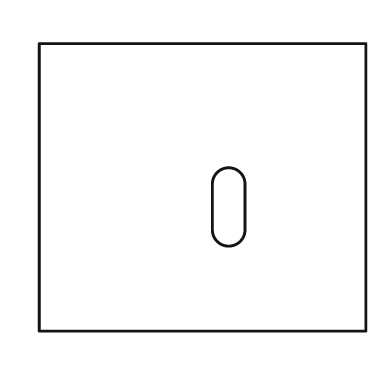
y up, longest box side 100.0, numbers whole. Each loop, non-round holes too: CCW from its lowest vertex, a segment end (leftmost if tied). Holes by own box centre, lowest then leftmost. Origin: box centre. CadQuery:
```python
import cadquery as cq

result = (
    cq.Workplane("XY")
    .moveTo(-50.0, -44.0)
    .lineTo(50.0, -44.0)
    .lineTo(50.0, 44.0)
    .lineTo(-50.0, 44.0)
    .close()
    .moveTo(3.0, -13.0)
    .threePointArc((8.0, -18.0), (13.0, -13.0))
    .lineTo(13.0, 1.0)
    .threePointArc((8.0, 6.0), (3.0, 1.0))
    .close()
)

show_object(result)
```